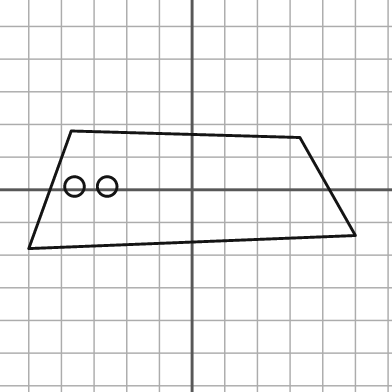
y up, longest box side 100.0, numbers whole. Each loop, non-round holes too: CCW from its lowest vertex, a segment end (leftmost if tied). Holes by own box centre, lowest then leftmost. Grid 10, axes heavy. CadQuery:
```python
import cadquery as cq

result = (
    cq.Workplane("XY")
    .moveTo(-50.0, -18.0)
    .lineTo(50.0, -14.0)
    .lineTo(33.0, 16.0)
    .lineTo(-37.0, 18.0)
    .close()
    .moveTo(-36.0, 1.0)
    .circle(3.0)
    .moveTo(-26.0, 1.0)
    .circle(3.0)
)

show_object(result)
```